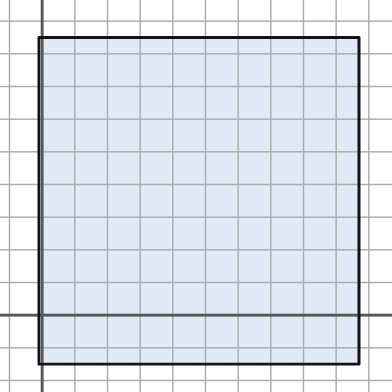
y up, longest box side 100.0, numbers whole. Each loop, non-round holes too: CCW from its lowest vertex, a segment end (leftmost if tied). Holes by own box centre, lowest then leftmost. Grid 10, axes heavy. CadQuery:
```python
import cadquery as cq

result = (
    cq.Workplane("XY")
    .moveTo(-1.0, -15.0)
    .lineTo(97.0, -15.0)
    .lineTo(97.0, 85.0)
    .lineTo(-1.0, 85.0)
    .close()
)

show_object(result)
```